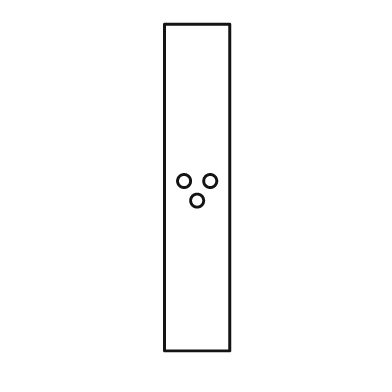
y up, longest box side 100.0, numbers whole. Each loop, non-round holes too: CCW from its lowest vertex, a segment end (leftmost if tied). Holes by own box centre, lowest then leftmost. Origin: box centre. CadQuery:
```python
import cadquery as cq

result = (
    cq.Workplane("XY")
    .moveTo(-10.0, -50.0)
    .lineTo(10.0, -50.0)
    .lineTo(10.0, 50.0)
    .lineTo(-10.0, 50.0)
    .close()
    .moveTo(0.0, -4.0)
    .circle(2.0)
    .moveTo(-4.0, 2.0)
    .circle(2.0)
    .moveTo(4.0, 2.0)
    .circle(2.0)
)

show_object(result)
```